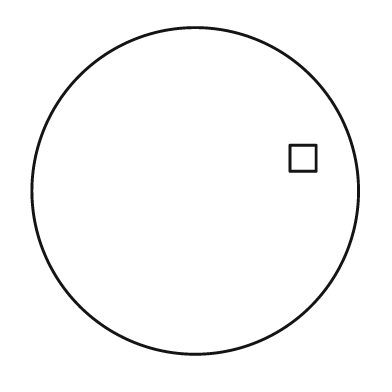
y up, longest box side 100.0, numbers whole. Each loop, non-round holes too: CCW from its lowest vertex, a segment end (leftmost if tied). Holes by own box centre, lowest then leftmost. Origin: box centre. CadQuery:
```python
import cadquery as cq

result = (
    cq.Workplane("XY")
    .moveTo(0.0, 0.0)
    .circle(50.0)
    .moveTo(29.0, 6.0)
    .lineTo(37.0, 6.0)
    .lineTo(37.0, 14.0)
    .lineTo(29.0, 14.0)
    .close()
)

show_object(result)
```